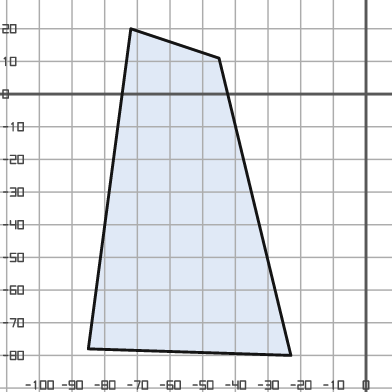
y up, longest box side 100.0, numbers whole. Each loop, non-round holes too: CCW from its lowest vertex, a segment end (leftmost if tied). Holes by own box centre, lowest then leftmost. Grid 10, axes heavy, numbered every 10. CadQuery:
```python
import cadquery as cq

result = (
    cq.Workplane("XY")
    .moveTo(-23.0, -80.0)
    .lineTo(-45.0, 11.0)
    .lineTo(-72.0, 20.0)
    .lineTo(-85.0, -78.0)
    .close()
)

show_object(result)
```